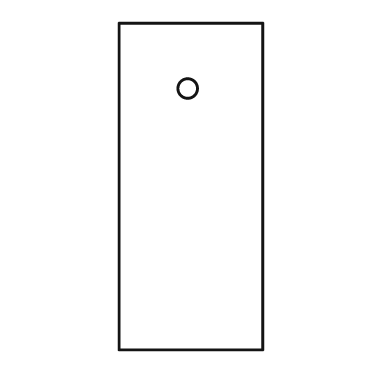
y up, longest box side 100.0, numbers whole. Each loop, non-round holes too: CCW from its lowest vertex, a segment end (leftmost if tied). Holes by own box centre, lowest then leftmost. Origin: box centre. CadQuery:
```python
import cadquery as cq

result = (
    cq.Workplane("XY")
    .moveTo(-22.0, -50.0)
    .lineTo(22.0, -50.0)
    .lineTo(22.0, 50.0)
    .lineTo(-22.0, 50.0)
    .close()
    .moveTo(-1.0, 30.0)
    .circle(3.0)
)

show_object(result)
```